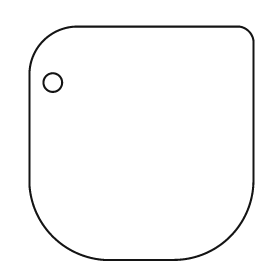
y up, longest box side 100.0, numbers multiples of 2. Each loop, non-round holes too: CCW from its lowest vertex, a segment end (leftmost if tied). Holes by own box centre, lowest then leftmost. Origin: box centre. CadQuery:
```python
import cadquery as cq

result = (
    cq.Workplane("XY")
    .moveTo(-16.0, -50.0)
    .lineTo(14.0, -50.0)
    .threePointArc((38.0, -40.0), (48.0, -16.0))
    .lineTo(48.0, 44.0)
    .threePointArc((46.0, 48.0), (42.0, 50.0))
    .lineTo(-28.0, 50.0)
    .threePointArc((-42.0, 44.0), (-48.0, 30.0))
    .lineTo(-48.0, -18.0)
    .threePointArc((-38.0, -40.0), (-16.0, -50.0))
    .close()
    .moveTo(-38.0, 26.0)
    .circle(4.0)
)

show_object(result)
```